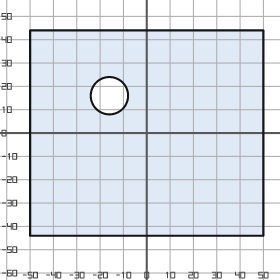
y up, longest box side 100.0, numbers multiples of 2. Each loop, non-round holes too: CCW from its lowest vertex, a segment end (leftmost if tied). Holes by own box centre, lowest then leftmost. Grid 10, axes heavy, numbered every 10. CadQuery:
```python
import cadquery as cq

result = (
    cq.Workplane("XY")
    .moveTo(-50.0, -44.0)
    .lineTo(50.0, -44.0)
    .lineTo(50.0, 44.0)
    .lineTo(-50.0, 44.0)
    .close()
    .moveTo(-16.0, 16.0)
    .circle(8.0)
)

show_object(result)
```